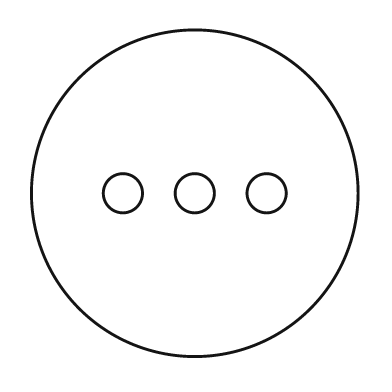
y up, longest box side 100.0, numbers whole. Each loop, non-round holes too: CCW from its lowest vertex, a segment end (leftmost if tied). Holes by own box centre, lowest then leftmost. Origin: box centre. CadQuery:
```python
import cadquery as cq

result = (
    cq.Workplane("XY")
    .moveTo(0.0, 0.0)
    .circle(50.0)
    .moveTo(-22.0, 0.0)
    .circle(6.0)
    .moveTo(0.0, 0.0)
    .circle(6.0)
    .moveTo(22.0, 0.0)
    .circle(6.0)
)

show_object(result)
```